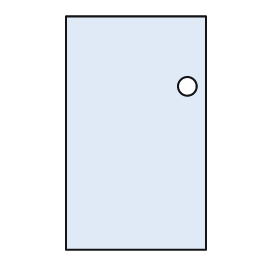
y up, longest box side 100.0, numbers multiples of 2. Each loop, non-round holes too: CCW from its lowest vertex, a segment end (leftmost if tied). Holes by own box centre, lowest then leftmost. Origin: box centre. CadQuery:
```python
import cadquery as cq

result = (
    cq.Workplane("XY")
    .moveTo(-30.0, -50.0)
    .lineTo(30.0, -50.0)
    .lineTo(30.0, 50.0)
    .lineTo(-30.0, 50.0)
    .close()
    .moveTo(22.0, 20.0)
    .circle(4.0)
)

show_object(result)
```